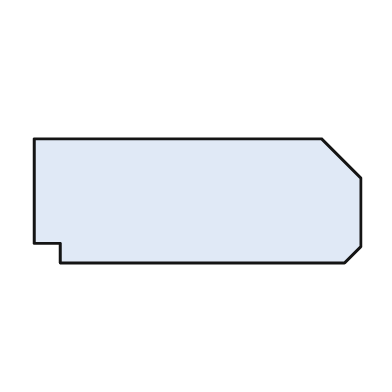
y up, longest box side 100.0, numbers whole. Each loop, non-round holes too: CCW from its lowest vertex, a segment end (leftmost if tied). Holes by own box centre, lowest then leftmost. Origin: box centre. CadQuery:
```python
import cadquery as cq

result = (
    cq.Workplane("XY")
    .moveTo(-42.0, -19.0)
    .lineTo(45.0, -19.0)
    .lineTo(50.0, -14.0)
    .lineTo(50.0, 7.0)
    .lineTo(38.0, 19.0)
    .lineTo(-50.0, 19.0)
    .lineTo(-50.0, -13.0)
    .lineTo(-42.0, -13.0)
    .close()
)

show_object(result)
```